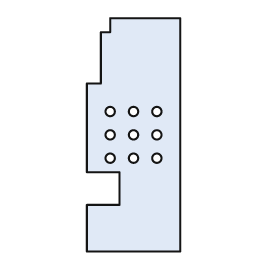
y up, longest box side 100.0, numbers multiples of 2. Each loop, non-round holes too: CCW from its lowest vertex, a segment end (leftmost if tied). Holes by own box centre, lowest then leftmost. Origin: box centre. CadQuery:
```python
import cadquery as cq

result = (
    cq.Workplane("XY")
    .moveTo(-20.0, -50.0)
    .lineTo(20.0, -50.0)
    .lineTo(20.0, 50.0)
    .lineTo(-10.0, 50.0)
    .lineTo(-10.0, 44.0)
    .lineTo(-14.0, 44.0)
    .lineTo(-14.0, 22.0)
    .lineTo(-20.0, 22.0)
    .lineTo(-20.0, -16.0)
    .lineTo(-6.0, -16.0)
    .lineTo(-6.0, -30.0)
    .lineTo(-20.0, -30.0)
    .close()
    .moveTo(-10.0, -10.0)
    .circle(2.0)
    .moveTo(0.0, -10.0)
    .circle(2.0)
    .moveTo(10.0, -10.0)
    .circle(2.0)
    .moveTo(-10.0, 0.0)
    .circle(2.0)
    .moveTo(0.0, 0.0)
    .circle(2.0)
    .moveTo(10.0, 0.0)
    .circle(2.0)
    .moveTo(-10.0, 10.0)
    .circle(2.0)
    .moveTo(0.0, 10.0)
    .circle(2.0)
    .moveTo(10.0, 10.0)
    .circle(2.0)
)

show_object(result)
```